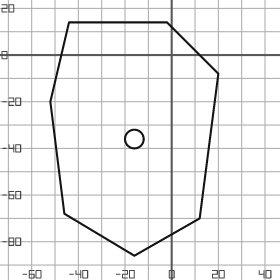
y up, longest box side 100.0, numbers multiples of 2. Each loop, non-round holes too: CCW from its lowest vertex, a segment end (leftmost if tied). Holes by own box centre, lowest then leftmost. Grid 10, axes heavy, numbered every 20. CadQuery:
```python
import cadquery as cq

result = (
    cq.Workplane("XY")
    .moveTo(-16.0, -86.0)
    .lineTo(12.0, -70.0)
    .lineTo(20.0, -8.0)
    .lineTo(-2.0, 14.0)
    .lineTo(-44.0, 14.0)
    .lineTo(-52.0, -20.0)
    .lineTo(-46.0, -68.0)
    .close()
    .moveTo(-16.0, -36.0)
    .circle(4.0)
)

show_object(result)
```